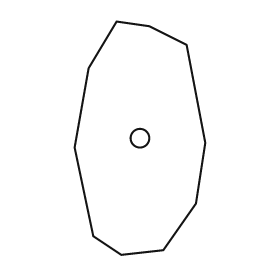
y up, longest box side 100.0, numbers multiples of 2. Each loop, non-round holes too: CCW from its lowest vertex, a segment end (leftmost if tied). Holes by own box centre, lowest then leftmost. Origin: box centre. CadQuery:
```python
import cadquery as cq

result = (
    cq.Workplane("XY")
    .moveTo(-8.0, -50.0)
    .lineTo(10.0, -48.0)
    .lineTo(24.0, -28.0)
    .lineTo(28.0, -2.0)
    .lineTo(20.0, 40.0)
    .lineTo(4.0, 48.0)
    .lineTo(-10.0, 50.0)
    .lineTo(-22.0, 30.0)
    .lineTo(-28.0, -4.0)
    .lineTo(-20.0, -42.0)
    .close()
    .moveTo(0.0, 0.0)
    .circle(4.0)
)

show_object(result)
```